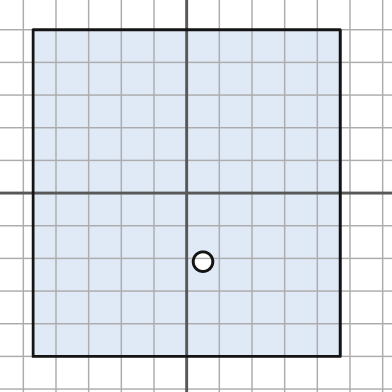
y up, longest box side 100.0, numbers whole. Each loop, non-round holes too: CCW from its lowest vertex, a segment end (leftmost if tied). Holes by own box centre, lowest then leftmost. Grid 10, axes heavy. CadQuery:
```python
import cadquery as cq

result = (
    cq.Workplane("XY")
    .moveTo(-47.0, -50.0)
    .lineTo(47.0, -50.0)
    .lineTo(47.0, 50.0)
    .lineTo(-47.0, 50.0)
    .close()
    .moveTo(5.0, -21.0)
    .circle(3.0)
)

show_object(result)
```